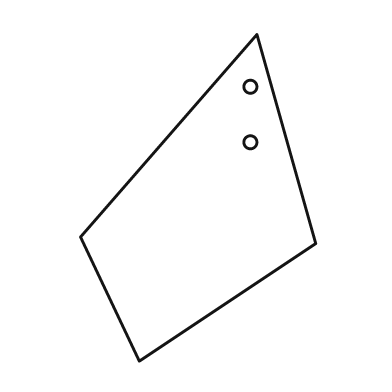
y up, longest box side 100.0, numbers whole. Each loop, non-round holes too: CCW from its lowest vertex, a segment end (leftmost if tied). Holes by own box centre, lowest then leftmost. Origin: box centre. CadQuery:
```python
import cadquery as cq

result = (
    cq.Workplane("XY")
    .moveTo(-18.0, -50.0)
    .lineTo(36.0, -14.0)
    .lineTo(18.0, 50.0)
    .lineTo(-36.0, -12.0)
    .close()
    .moveTo(16.0, 17.0)
    .circle(2.0)
    .moveTo(16.0, 34.0)
    .circle(2.0)
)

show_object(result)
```